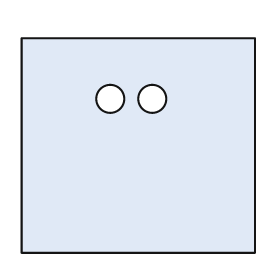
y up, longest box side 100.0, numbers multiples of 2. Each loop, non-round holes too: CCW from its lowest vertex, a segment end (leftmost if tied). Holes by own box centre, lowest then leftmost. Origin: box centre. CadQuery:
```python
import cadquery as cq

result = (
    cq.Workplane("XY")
    .moveTo(-50.0, -46.0)
    .lineTo(50.0, -46.0)
    .lineTo(50.0, 46.0)
    .lineTo(-50.0, 46.0)
    .close()
    .moveTo(-12.0, 20.0)
    .circle(6.0)
    .moveTo(6.0, 20.0)
    .circle(6.0)
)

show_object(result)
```